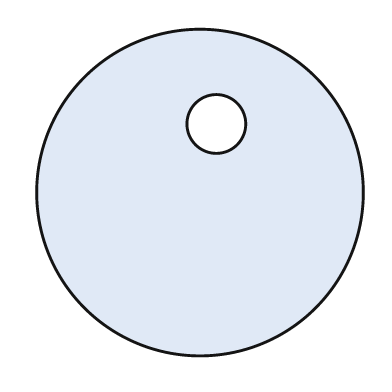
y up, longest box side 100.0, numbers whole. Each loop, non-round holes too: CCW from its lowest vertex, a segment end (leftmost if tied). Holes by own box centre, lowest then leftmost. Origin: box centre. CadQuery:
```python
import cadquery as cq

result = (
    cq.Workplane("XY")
    .moveTo(0.0, 0.0)
    .circle(50.0)
    .moveTo(5.0, 21.0)
    .circle(9.0)
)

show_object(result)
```